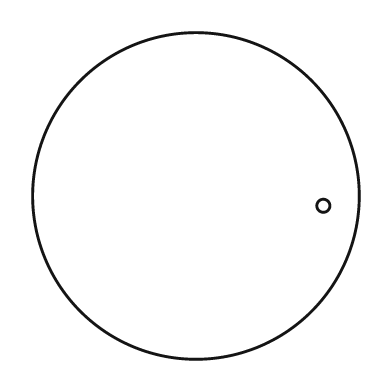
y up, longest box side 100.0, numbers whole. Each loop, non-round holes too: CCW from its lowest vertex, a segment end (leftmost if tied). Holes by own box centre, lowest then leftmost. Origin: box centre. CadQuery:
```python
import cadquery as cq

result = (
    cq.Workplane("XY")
    .moveTo(0.0, 0.0)
    .circle(50.0)
    .moveTo(39.0, -3.0)
    .circle(2.0)
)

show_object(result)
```